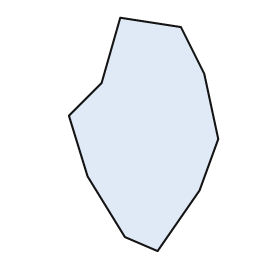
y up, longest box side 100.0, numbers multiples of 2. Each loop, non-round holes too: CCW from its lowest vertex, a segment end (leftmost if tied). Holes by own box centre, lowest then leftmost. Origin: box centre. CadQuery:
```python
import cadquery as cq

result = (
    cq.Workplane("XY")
    .moveTo(6.0, -50.0)
    .lineTo(24.0, -24.0)
    .lineTo(32.0, -2.0)
    .lineTo(26.0, 26.0)
    .lineTo(16.0, 46.0)
    .lineTo(-10.0, 50.0)
    .lineTo(-18.0, 22.0)
    .lineTo(-32.0, 8.0)
    .lineTo(-24.0, -18.0)
    .lineTo(-8.0, -44.0)
    .close()
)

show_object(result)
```